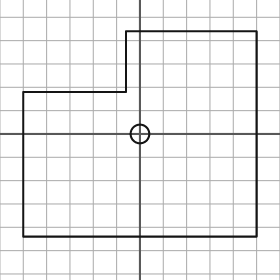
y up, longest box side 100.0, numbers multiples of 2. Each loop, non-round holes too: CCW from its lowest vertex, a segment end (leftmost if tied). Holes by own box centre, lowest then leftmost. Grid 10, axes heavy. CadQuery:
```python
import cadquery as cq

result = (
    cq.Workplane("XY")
    .moveTo(-50.0, -44.0)
    .lineTo(50.0, -44.0)
    .lineTo(50.0, 44.0)
    .lineTo(-6.0, 44.0)
    .lineTo(-6.0, 18.0)
    .lineTo(-50.0, 18.0)
    .close()
    .moveTo(0.0, 0.0)
    .circle(4.0)
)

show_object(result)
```